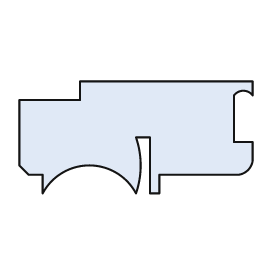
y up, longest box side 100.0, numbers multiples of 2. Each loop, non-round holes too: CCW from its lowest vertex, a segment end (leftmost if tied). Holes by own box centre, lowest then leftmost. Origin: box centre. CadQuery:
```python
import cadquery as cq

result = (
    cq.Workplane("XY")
    .moveTo(-40.0, -24.0)
    .threePointArc((-20.0, -12.0), (0.0, -24.0))
    .threePointArc((2.0, -12.0), (0.0, 0.0))
    .lineTo(6.0, 0.0)
    .lineTo(6.0, -24.0)
    .lineTo(10.0, -24.0)
    .lineTo(10.0, -16.0)
    .lineTo(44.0, -16.0)
    .threePointArc((48.0, -14.0), (50.0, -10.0))
    .lineTo(50.0, -2.0)
    .lineTo(42.0, -2.0)
    .lineTo(42.0, 18.0)
    .threePointArc((46.0, 20.0), (50.0, 18.0))
    .lineTo(50.0, 24.0)
    .lineTo(-24.0, 24.0)
    .lineTo(-24.0, 16.0)
    .lineTo(-50.0, 16.0)
    .lineTo(-50.0, -12.0)
    .lineTo(-46.0, -16.0)
    .lineTo(-40.0, -16.0)
    .close()
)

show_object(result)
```